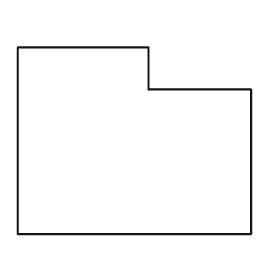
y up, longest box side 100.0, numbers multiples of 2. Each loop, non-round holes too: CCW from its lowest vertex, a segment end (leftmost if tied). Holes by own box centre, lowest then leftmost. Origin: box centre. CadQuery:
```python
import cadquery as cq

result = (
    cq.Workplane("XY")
    .moveTo(-50.0, -40.0)
    .lineTo(50.0, -40.0)
    .lineTo(50.0, 22.0)
    .lineTo(6.0, 22.0)
    .lineTo(6.0, 40.0)
    .lineTo(-50.0, 40.0)
    .close()
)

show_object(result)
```